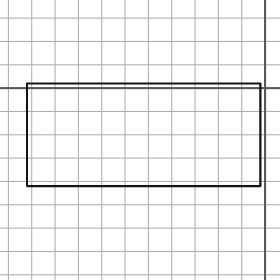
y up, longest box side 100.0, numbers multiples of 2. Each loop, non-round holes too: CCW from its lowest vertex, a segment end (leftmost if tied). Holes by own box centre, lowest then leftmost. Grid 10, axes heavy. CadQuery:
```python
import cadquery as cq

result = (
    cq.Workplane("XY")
    .moveTo(-102.0, -42.0)
    .lineTo(-2.0, -42.0)
    .lineTo(-2.0, 2.0)
    .lineTo(-102.0, 2.0)
    .close()
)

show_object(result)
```